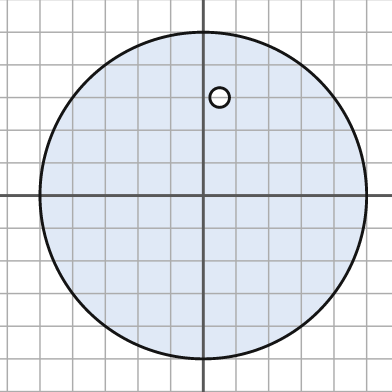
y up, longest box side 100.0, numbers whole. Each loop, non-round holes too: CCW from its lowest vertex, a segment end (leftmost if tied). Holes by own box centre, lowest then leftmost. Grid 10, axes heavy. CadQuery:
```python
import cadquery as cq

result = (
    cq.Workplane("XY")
    .moveTo(0.0, 0.0)
    .circle(50.0)
    .moveTo(5.0, 30.0)
    .circle(3.0)
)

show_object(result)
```